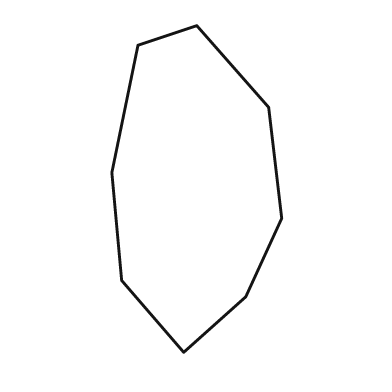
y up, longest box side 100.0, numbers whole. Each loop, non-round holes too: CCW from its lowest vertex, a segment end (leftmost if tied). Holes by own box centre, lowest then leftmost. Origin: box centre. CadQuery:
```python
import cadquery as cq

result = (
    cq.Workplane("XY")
    .moveTo(-4.0, -50.0)
    .lineTo(15.0, -33.0)
    .lineTo(26.0, -9.0)
    .lineTo(22.0, 25.0)
    .lineTo(0.0, 50.0)
    .lineTo(-18.0, 44.0)
    .lineTo(-26.0, 5.0)
    .lineTo(-23.0, -28.0)
    .close()
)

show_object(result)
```